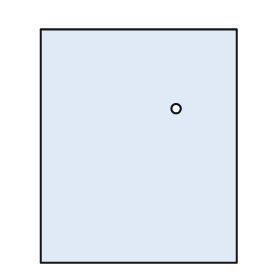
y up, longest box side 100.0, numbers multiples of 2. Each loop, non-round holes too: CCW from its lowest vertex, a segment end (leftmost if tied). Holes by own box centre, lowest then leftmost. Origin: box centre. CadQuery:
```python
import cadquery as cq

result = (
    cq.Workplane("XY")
    .moveTo(-42.0, -50.0)
    .lineTo(42.0, -50.0)
    .lineTo(42.0, 50.0)
    .lineTo(-42.0, 50.0)
    .close()
    .moveTo(16.0, 16.0)
    .circle(2.0)
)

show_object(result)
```